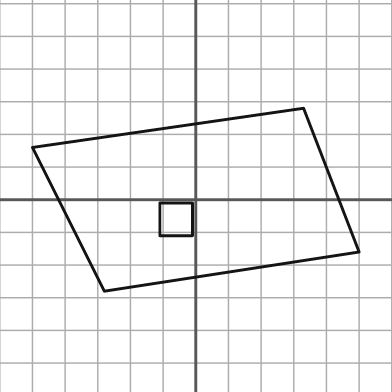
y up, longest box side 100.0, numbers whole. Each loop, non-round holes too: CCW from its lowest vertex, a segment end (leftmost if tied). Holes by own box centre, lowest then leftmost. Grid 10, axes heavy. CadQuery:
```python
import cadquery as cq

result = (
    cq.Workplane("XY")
    .moveTo(-28.0, -28.0)
    .lineTo(50.0, -16.0)
    .lineTo(33.0, 28.0)
    .lineTo(-50.0, 16.0)
    .close()
    .moveTo(-11.0, -11.0)
    .lineTo(-1.0, -11.0)
    .lineTo(-1.0, -1.0)
    .lineTo(-11.0, -1.0)
    .close()
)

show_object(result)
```